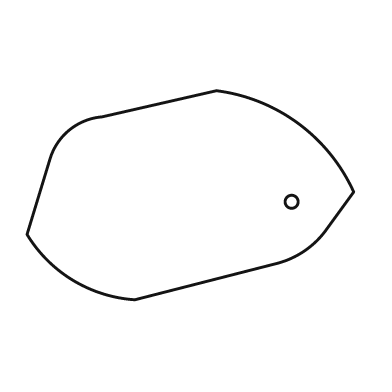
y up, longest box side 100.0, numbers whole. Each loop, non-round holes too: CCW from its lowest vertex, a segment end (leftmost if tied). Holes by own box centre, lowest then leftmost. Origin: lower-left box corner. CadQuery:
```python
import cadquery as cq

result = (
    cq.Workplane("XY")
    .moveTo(33.0, 0.0)
    .lineTo(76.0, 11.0)
    .threePointArc((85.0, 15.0), (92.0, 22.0))
    .lineTo(100.0, 33.0)
    .threePointArc((83.0, 54.0), (58.0, 64.0))
    .lineTo(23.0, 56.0)
    .threePointArc((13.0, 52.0), (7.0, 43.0))
    .lineTo(0.0, 20.0)
    .threePointArc((14.0, 6.0), (33.0, 0.0))
    .close()
    .moveTo(81.0, 30.0)
    .circle(2.0)
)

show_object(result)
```